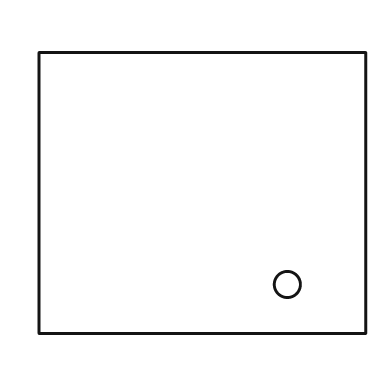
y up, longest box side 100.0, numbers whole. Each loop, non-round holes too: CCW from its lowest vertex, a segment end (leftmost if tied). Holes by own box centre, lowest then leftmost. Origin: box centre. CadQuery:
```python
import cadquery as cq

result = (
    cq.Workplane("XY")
    .moveTo(-50.0, -43.0)
    .lineTo(50.0, -43.0)
    .lineTo(50.0, 43.0)
    .lineTo(-50.0, 43.0)
    .close()
    .moveTo(26.0, -28.0)
    .circle(4.0)
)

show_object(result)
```